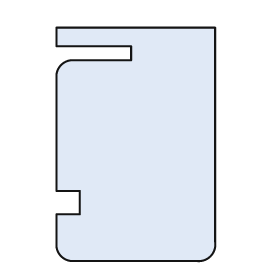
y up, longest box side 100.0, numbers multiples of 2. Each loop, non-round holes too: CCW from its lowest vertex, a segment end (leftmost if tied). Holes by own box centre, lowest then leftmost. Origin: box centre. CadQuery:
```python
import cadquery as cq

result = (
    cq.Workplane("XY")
    .moveTo(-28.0, -50.0)
    .lineTo(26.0, -50.0)
    .threePointArc((32.0, -48.0), (34.0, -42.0))
    .lineTo(34.0, 50.0)
    .lineTo(-34.0, 50.0)
    .lineTo(-34.0, 42.0)
    .lineTo(-2.0, 42.0)
    .lineTo(-2.0, 36.0)
    .lineTo(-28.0, 36.0)
    .threePointArc((-32.0, 34.0), (-34.0, 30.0))
    .lineTo(-34.0, -20.0)
    .lineTo(-24.0, -20.0)
    .lineTo(-24.0, -30.0)
    .lineTo(-34.0, -30.0)
    .lineTo(-34.0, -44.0)
    .threePointArc((-32.0, -48.0), (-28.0, -50.0))
    .close()
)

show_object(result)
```